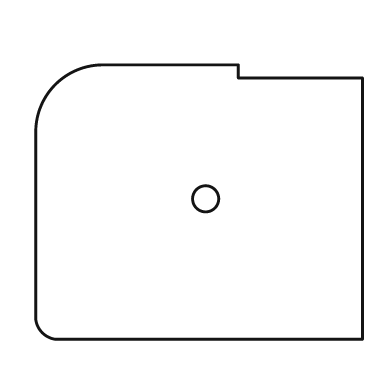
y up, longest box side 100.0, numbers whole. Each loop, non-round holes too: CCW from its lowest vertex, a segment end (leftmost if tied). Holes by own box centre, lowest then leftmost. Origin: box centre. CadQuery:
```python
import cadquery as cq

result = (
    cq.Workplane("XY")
    .moveTo(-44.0, -42.0)
    .lineTo(50.0, -42.0)
    .lineTo(50.0, 38.0)
    .lineTo(12.0, 38.0)
    .lineTo(12.0, 42.0)
    .lineTo(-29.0, 42.0)
    .threePointArc((-44.0, 36.0), (-50.0, 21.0))
    .lineTo(-50.0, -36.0)
    .threePointArc((-48.0, -40.0), (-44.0, -42.0))
    .close()
    .moveTo(2.0, 1.0)
    .circle(4.0)
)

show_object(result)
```